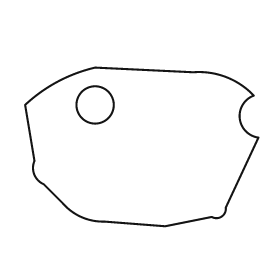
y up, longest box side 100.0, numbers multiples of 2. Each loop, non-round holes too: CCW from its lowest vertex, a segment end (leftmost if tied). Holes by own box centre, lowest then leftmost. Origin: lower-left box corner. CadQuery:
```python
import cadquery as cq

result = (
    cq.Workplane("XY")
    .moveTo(60.0, 0.0)
    .lineTo(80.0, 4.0)
    .threePointArc((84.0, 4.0), (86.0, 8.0))
    .lineTo(100.0, 38.0)
    .threePointArc((92.0, 46.0), (98.0, 56.0))
    .threePointArc((86.0, 64.0), (72.0, 66.0))
    .lineTo(30.0, 68.0)
    .threePointArc((14.0, 62.0), (0.0, 52.0))
    .lineTo(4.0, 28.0)
    .threePointArc((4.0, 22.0), (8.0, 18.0))
    .lineTo(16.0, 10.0)
    .threePointArc((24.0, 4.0), (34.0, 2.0))
    .close()
    .moveTo(30.0, 52.0)
    .circle(8.0)
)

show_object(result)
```